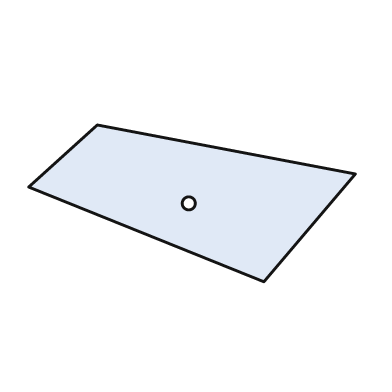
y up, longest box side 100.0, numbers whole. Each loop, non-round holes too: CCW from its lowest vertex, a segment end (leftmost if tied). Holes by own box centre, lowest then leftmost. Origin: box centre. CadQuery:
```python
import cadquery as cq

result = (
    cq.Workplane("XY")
    .moveTo(22.0, -24.0)
    .lineTo(50.0, 9.0)
    .lineTo(-29.0, 24.0)
    .lineTo(-50.0, 5.0)
    .close()
    .moveTo(-1.0, 0.0)
    .circle(2.0)
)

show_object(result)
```